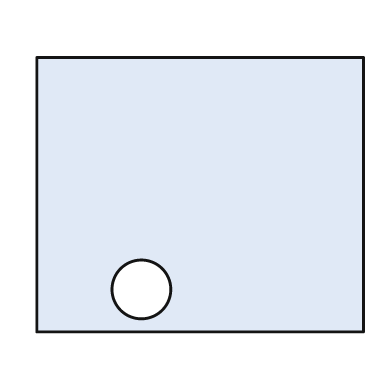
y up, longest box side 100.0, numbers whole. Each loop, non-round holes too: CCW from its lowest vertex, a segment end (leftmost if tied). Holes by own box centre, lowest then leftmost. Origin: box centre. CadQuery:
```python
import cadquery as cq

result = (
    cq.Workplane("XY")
    .moveTo(-50.0, -42.0)
    .lineTo(50.0, -42.0)
    .lineTo(50.0, 42.0)
    .lineTo(-50.0, 42.0)
    .close()
    .moveTo(-18.0, -29.0)
    .circle(9.0)
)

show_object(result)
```